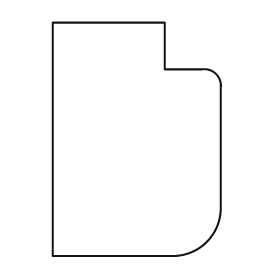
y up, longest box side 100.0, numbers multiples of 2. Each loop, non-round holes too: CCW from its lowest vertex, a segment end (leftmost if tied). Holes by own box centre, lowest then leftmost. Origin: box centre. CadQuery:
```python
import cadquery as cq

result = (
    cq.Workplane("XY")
    .moveTo(-36.0, -50.0)
    .lineTo(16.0, -50.0)
    .threePointArc((30.0, -44.0), (36.0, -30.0))
    .lineTo(36.0, 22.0)
    .threePointArc((34.0, 28.0), (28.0, 30.0))
    .lineTo(12.0, 30.0)
    .lineTo(12.0, 50.0)
    .lineTo(-36.0, 50.0)
    .close()
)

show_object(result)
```